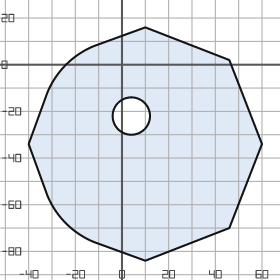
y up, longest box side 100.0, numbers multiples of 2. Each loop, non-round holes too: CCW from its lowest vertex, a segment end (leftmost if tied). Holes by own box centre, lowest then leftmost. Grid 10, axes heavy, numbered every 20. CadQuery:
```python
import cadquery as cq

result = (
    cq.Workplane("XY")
    .moveTo(10.0, -84.0)
    .lineTo(46.0, -70.0)
    .lineTo(60.0, -34.0)
    .lineTo(46.0, 2.0)
    .lineTo(10.0, 16.0)
    .lineTo(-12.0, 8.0)
    .threePointArc((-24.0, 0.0), (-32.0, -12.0))
    .lineTo(-40.0, -34.0)
    .lineTo(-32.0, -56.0)
    .threePointArc((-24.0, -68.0), (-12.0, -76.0))
    .close()
    .moveTo(4.0, -22.0)
    .circle(8.0)
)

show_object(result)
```